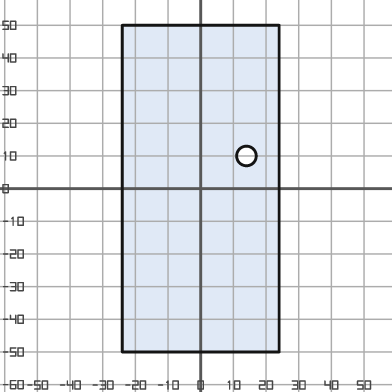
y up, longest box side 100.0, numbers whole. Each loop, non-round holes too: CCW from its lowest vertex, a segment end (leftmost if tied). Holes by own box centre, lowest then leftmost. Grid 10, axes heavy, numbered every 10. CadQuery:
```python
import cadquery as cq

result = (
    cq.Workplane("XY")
    .moveTo(-24.0, -50.0)
    .lineTo(24.0, -50.0)
    .lineTo(24.0, 50.0)
    .lineTo(-24.0, 50.0)
    .close()
    .moveTo(14.0, 10.0)
    .circle(3.0)
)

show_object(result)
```